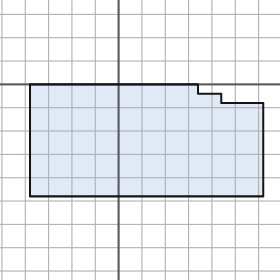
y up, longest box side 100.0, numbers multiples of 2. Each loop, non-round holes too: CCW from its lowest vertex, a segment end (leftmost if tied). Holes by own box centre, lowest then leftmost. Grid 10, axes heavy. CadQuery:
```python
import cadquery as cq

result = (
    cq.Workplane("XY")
    .moveTo(-38.0, -48.0)
    .lineTo(62.0, -48.0)
    .lineTo(62.0, -8.0)
    .lineTo(44.0, -8.0)
    .lineTo(44.0, -4.0)
    .lineTo(34.0, -4.0)
    .lineTo(34.0, 0.0)
    .lineTo(-38.0, 0.0)
    .close()
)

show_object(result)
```